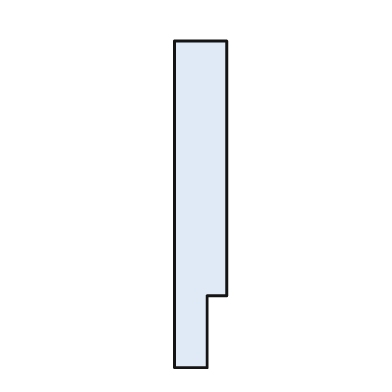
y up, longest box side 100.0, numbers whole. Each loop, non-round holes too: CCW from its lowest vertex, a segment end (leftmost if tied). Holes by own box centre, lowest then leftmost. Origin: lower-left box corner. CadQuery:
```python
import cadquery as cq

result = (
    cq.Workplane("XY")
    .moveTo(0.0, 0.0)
    .lineTo(10.0, 0.0)
    .lineTo(10.0, 22.0)
    .lineTo(16.0, 22.0)
    .lineTo(16.0, 100.0)
    .lineTo(0.0, 100.0)
    .close()
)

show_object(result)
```